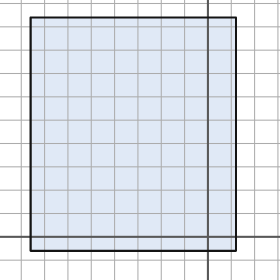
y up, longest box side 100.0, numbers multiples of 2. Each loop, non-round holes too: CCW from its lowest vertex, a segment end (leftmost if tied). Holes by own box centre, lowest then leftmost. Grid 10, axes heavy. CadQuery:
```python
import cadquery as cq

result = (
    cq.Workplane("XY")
    .moveTo(-76.0, -6.0)
    .lineTo(12.0, -6.0)
    .lineTo(12.0, 94.0)
    .lineTo(-76.0, 94.0)
    .close()
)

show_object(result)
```